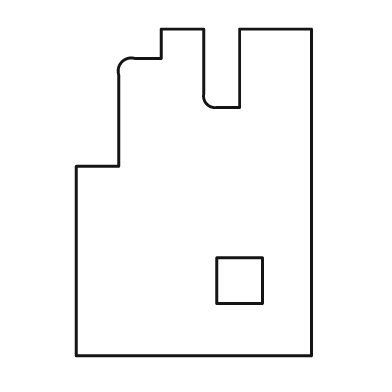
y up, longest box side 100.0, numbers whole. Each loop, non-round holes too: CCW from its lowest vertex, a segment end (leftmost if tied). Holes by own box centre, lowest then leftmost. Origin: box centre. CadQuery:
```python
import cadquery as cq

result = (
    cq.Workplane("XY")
    .moveTo(-36.0, -50.0)
    .lineTo(36.0, -50.0)
    .lineTo(36.0, 50.0)
    .lineTo(14.0, 50.0)
    .lineTo(14.0, 26.0)
    .lineTo(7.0, 26.0)
    .threePointArc((4.0, 27.0), (3.0, 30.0))
    .lineTo(3.0, 50.0)
    .lineTo(-10.0, 50.0)
    .lineTo(-10.0, 41.0)
    .lineTo(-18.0, 41.0)
    .threePointArc((-22.0, 40.0), (-23.0, 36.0))
    .lineTo(-23.0, 8.0)
    .lineTo(-36.0, 8.0)
    .close()
    .moveTo(7.0, -34.0)
    .lineTo(21.0, -34.0)
    .lineTo(21.0, -20.0)
    .lineTo(7.0, -20.0)
    .close()
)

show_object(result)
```